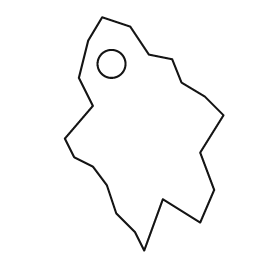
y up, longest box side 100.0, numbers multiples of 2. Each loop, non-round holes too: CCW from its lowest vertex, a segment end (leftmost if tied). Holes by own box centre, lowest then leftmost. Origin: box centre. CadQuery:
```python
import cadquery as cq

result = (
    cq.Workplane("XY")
    .moveTo(0.0, -50.0)
    .lineTo(8.0, -28.0)
    .lineTo(24.0, -38.0)
    .lineTo(30.0, -24.0)
    .lineTo(24.0, -8.0)
    .lineTo(34.0, 8.0)
    .lineTo(26.0, 16.0)
    .lineTo(16.0, 22.0)
    .lineTo(12.0, 32.0)
    .lineTo(2.0, 34.0)
    .lineTo(-6.0, 46.0)
    .lineTo(-18.0, 50.0)
    .lineTo(-24.0, 40.0)
    .lineTo(-28.0, 24.0)
    .lineTo(-22.0, 12.0)
    .lineTo(-34.0, -2.0)
    .lineTo(-30.0, -10.0)
    .lineTo(-22.0, -14.0)
    .lineTo(-16.0, -22.0)
    .lineTo(-12.0, -34.0)
    .lineTo(-4.0, -42.0)
    .close()
    .moveTo(-14.0, 30.0)
    .circle(6.0)
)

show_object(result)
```